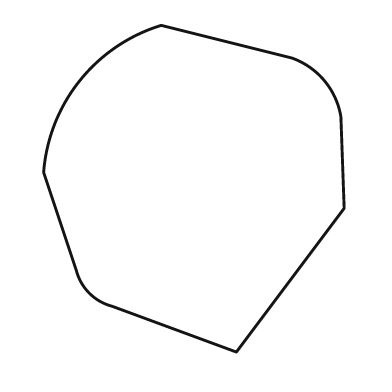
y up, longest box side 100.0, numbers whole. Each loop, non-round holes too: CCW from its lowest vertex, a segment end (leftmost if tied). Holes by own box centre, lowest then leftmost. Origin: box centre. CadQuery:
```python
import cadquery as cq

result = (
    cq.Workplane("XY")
    .moveTo(13.0, -50.0)
    .lineTo(46.0, -6.0)
    .lineTo(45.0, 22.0)
    .threePointArc((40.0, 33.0), (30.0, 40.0))
    .lineTo(-10.0, 50.0)
    .threePointArc((-35.0, 33.0), (-46.0, 5.0))
    .lineTo(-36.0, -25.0)
    .threePointArc((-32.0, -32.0), (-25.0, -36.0))
    .close()
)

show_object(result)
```